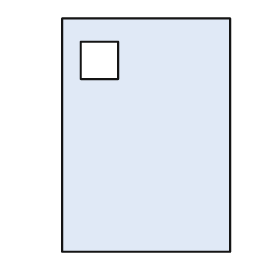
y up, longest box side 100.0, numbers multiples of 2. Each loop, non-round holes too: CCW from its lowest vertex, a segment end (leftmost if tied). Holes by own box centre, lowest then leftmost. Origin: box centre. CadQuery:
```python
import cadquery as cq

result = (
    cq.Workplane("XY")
    .moveTo(-36.0, -50.0)
    .lineTo(36.0, -50.0)
    .lineTo(36.0, 50.0)
    .lineTo(-36.0, 50.0)
    .close()
    .moveTo(-28.0, 24.0)
    .lineTo(-12.0, 24.0)
    .lineTo(-12.0, 40.0)
    .lineTo(-28.0, 40.0)
    .close()
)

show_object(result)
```